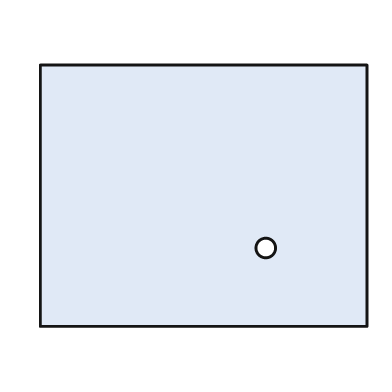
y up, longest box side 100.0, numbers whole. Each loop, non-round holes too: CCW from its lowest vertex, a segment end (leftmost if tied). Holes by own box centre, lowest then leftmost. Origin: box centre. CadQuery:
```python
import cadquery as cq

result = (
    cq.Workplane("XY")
    .moveTo(-50.0, -40.0)
    .lineTo(50.0, -40.0)
    .lineTo(50.0, 40.0)
    .lineTo(-50.0, 40.0)
    .close()
    .moveTo(19.0, -16.0)
    .circle(3.0)
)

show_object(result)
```